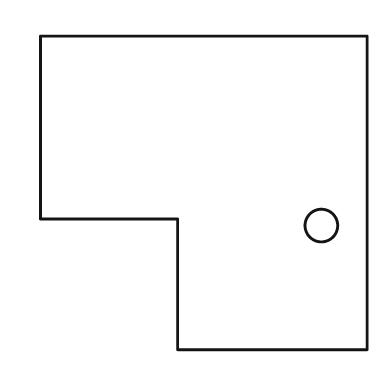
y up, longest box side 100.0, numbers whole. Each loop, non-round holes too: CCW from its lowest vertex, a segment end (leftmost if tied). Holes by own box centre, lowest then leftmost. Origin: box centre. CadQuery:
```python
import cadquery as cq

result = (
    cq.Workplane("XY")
    .moveTo(-8.0, -48.0)
    .lineTo(50.0, -48.0)
    .lineTo(50.0, 48.0)
    .lineTo(-50.0, 48.0)
    .lineTo(-50.0, -8.0)
    .lineTo(-8.0, -8.0)
    .close()
    .moveTo(36.0, -10.0)
    .circle(5.0)
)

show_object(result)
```